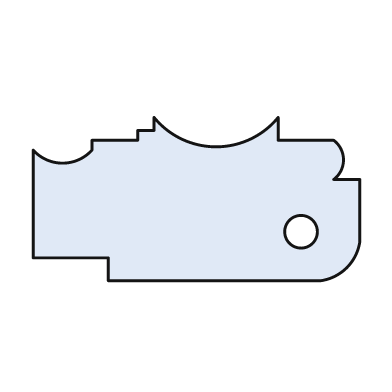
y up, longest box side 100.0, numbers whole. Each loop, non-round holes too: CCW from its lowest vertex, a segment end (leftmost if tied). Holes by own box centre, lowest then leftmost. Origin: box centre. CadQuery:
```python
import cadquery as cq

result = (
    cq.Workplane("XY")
    .moveTo(-27.0, -25.0)
    .lineTo(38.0, -25.0)
    .threePointArc((46.0, -21.0), (50.0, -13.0))
    .lineTo(50.0, 6.0)
    .lineTo(42.0, 6.0)
    .threePointArc((45.0, 12.0), (42.0, 18.0))
    .lineTo(25.0, 18.0)
    .lineTo(25.0, 25.0)
    .threePointArc((6.0, 16.0), (-13.0, 25.0))
    .lineTo(-13.0, 21.0)
    .lineTo(-18.0, 21.0)
    .lineTo(-18.0, 18.0)
    .lineTo(-32.0, 18.0)
    .lineTo(-32.0, 15.0)
    .threePointArc((-41.0, 11.0), (-50.0, 15.0))
    .lineTo(-50.0, -18.0)
    .lineTo(-27.0, -18.0)
    .close()
    .moveTo(32.0, -10.0)
    .circle(5.0)
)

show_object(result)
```